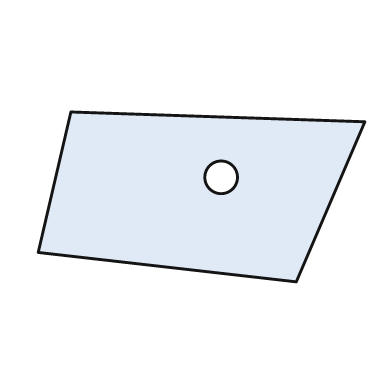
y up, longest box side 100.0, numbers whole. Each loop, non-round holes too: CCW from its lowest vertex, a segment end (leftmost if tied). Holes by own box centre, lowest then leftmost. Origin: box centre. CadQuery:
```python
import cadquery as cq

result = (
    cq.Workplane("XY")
    .moveTo(29.0, -26.0)
    .lineTo(50.0, 23.0)
    .lineTo(-40.0, 26.0)
    .lineTo(-50.0, -17.0)
    .close()
    .moveTo(6.0, 6.0)
    .circle(5.0)
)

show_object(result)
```